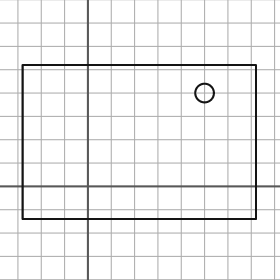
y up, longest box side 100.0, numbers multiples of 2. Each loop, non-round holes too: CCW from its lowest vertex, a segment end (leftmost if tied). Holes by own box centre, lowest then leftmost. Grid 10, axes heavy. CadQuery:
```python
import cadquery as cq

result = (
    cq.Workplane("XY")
    .moveTo(-28.0, -14.0)
    .lineTo(72.0, -14.0)
    .lineTo(72.0, 52.0)
    .lineTo(-28.0, 52.0)
    .close()
    .moveTo(50.0, 40.0)
    .circle(4.0)
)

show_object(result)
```